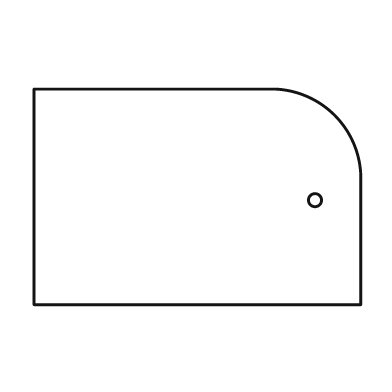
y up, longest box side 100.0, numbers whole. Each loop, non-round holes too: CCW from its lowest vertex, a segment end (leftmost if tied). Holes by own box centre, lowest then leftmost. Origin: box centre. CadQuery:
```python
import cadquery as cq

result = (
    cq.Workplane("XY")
    .moveTo(-50.0, -33.0)
    .lineTo(50.0, -33.0)
    .lineTo(50.0, 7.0)
    .threePointArc((42.0, 25.0), (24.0, 33.0))
    .lineTo(-50.0, 33.0)
    .close()
    .moveTo(36.0, -1.0)
    .circle(2.0)
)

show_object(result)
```